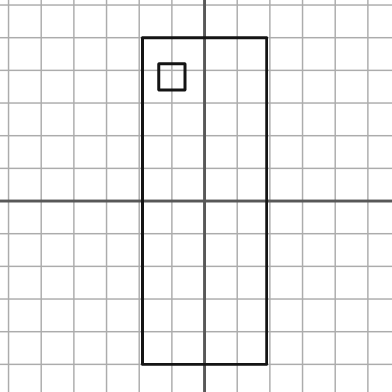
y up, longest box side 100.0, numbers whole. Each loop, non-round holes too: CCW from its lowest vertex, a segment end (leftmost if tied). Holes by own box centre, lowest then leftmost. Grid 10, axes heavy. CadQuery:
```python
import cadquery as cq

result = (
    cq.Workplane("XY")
    .moveTo(-19.0, -50.0)
    .lineTo(19.0, -50.0)
    .lineTo(19.0, 50.0)
    .lineTo(-19.0, 50.0)
    .close()
    .moveTo(-14.0, 34.0)
    .lineTo(-6.0, 34.0)
    .lineTo(-6.0, 42.0)
    .lineTo(-14.0, 42.0)
    .close()
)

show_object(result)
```